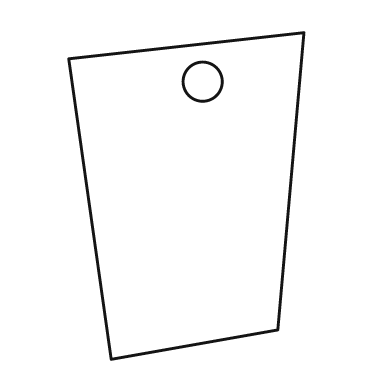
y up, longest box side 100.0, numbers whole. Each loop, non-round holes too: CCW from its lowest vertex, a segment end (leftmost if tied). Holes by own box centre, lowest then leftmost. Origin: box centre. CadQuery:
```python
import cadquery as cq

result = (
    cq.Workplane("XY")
    .moveTo(-23.0, -50.0)
    .lineTo(28.0, -41.0)
    .lineTo(36.0, 50.0)
    .lineTo(-36.0, 42.0)
    .close()
    .moveTo(5.0, 35.0)
    .circle(6.0)
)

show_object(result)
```